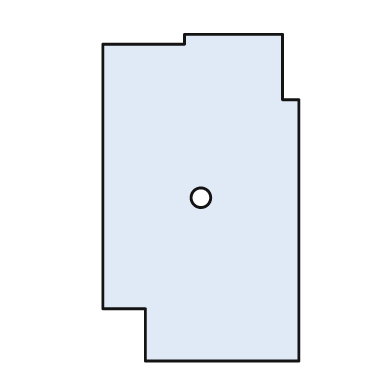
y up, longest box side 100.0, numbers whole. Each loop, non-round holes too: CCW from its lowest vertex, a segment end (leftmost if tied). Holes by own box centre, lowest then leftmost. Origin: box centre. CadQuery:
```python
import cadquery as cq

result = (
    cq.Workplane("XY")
    .moveTo(-17.0, -50.0)
    .lineTo(30.0, -50.0)
    .lineTo(30.0, 30.0)
    .lineTo(25.0, 30.0)
    .lineTo(25.0, 50.0)
    .lineTo(-5.0, 50.0)
    .lineTo(-5.0, 47.0)
    .lineTo(-30.0, 47.0)
    .lineTo(-30.0, -34.0)
    .lineTo(-17.0, -34.0)
    .close()
    .moveTo(0.0, 0.0)
    .circle(3.0)
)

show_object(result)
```